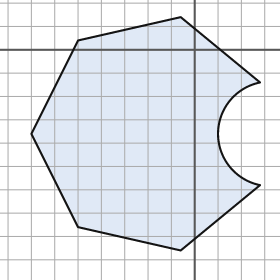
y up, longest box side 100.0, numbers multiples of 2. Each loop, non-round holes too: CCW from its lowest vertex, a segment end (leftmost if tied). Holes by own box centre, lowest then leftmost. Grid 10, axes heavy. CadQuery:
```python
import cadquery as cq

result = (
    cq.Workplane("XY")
    .moveTo(-6.0, -86.0)
    .lineTo(28.0, -58.0)
    .threePointArc((10.0, -36.0), (28.0, -14.0))
    .lineTo(-6.0, 14.0)
    .lineTo(-50.0, 4.0)
    .lineTo(-70.0, -36.0)
    .lineTo(-50.0, -76.0)
    .close()
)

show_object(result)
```